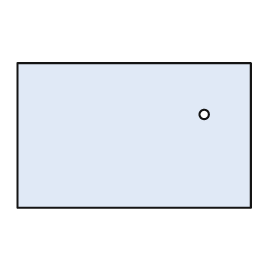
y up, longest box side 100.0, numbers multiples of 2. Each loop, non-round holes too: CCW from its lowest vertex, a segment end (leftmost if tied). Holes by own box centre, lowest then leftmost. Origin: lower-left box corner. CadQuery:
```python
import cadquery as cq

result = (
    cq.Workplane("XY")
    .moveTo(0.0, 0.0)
    .lineTo(100.0, 0.0)
    .lineTo(100.0, 62.0)
    .lineTo(0.0, 62.0)
    .close()
    .moveTo(80.0, 40.0)
    .circle(2.0)
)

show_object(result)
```